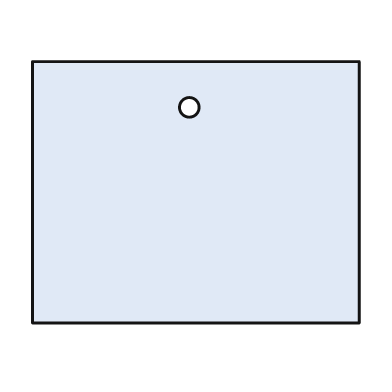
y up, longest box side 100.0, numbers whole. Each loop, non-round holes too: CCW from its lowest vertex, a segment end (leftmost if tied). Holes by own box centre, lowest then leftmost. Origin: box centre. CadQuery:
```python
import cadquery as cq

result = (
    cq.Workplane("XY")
    .moveTo(-50.0, -40.0)
    .lineTo(50.0, -40.0)
    .lineTo(50.0, 40.0)
    .lineTo(-50.0, 40.0)
    .close()
    .moveTo(-2.0, 26.0)
    .circle(3.0)
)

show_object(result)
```